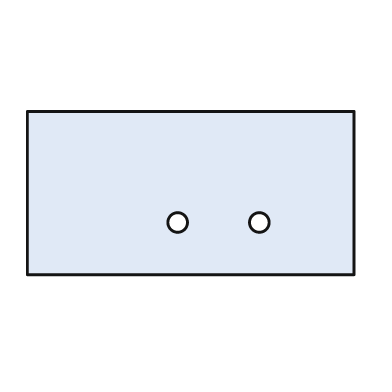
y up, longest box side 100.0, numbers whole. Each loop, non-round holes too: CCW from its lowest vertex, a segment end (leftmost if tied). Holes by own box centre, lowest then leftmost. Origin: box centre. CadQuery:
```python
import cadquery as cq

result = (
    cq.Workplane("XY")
    .moveTo(-50.0, -25.0)
    .lineTo(50.0, -25.0)
    .lineTo(50.0, 25.0)
    .lineTo(-50.0, 25.0)
    .close()
    .moveTo(-4.0, -9.0)
    .circle(3.0)
    .moveTo(21.0, -9.0)
    .circle(3.0)
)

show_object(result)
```